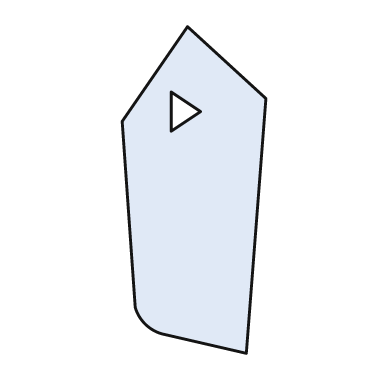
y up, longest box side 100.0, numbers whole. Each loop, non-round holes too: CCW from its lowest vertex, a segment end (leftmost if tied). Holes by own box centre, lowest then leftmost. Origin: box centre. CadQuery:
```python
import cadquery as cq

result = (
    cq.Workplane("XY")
    .moveTo(16.0, -50.0)
    .lineTo(22.0, 28.0)
    .lineTo(-2.0, 50.0)
    .lineTo(-22.0, 21.0)
    .lineTo(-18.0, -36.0)
    .threePointArc((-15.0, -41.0), (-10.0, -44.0))
    .close()
    .moveTo(-7.0, 18.0)
    .lineTo(2.0, 24.0)
    .lineTo(-7.0, 30.0)
    .close()
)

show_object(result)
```